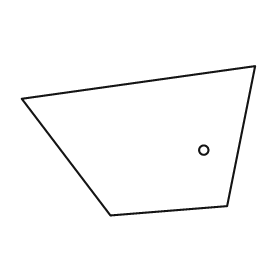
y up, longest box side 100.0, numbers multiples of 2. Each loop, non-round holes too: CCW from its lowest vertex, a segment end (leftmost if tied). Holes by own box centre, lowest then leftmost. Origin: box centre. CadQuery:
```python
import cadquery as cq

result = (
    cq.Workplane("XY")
    .moveTo(-12.0, -32.0)
    .lineTo(38.0, -28.0)
    .lineTo(50.0, 32.0)
    .lineTo(-50.0, 18.0)
    .close()
    .moveTo(28.0, -4.0)
    .circle(2.0)
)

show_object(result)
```